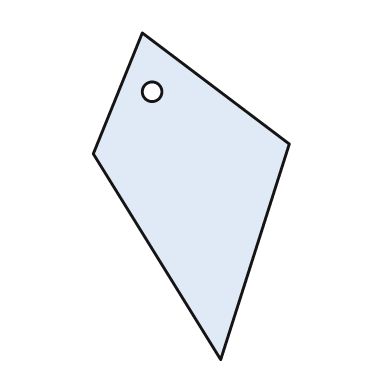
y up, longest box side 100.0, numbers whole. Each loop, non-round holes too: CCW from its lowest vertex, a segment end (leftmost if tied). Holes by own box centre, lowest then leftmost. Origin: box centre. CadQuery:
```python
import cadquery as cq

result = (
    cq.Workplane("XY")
    .moveTo(9.0, -50.0)
    .lineTo(30.0, 16.0)
    .lineTo(-15.0, 50.0)
    .lineTo(-30.0, 13.0)
    .close()
    .moveTo(-12.0, 32.0)
    .circle(3.0)
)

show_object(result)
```